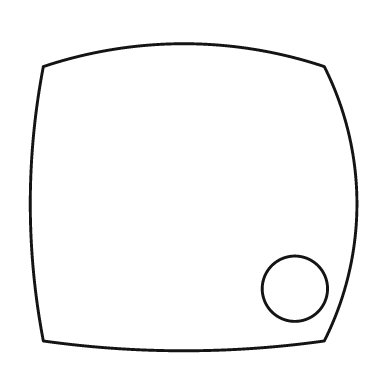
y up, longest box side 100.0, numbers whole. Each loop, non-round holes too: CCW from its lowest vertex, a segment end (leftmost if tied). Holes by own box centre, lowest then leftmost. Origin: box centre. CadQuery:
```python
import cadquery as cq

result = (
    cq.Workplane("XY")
    .moveTo(-46.0, -44.0)
    .threePointArc((-3.0, -47.0), (40.0, -44.0))
    .threePointArc((50.0, -2.0), (40.0, 40.0))
    .threePointArc((-3.0, 47.0), (-46.0, 40.0))
    .threePointArc((-50.0, -2.0), (-46.0, -44.0))
    .close()
    .moveTo(31.0, -28.0)
    .circle(10.0)
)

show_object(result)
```